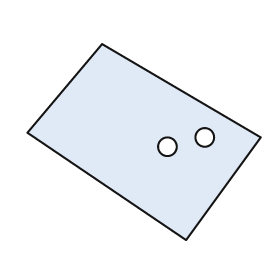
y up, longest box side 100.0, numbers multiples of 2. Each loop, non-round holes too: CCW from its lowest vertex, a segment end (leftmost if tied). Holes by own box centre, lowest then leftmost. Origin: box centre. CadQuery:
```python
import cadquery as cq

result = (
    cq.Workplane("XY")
    .moveTo(18.0, -42.0)
    .lineTo(50.0, 2.0)
    .lineTo(-18.0, 42.0)
    .lineTo(-50.0, 4.0)
    .close()
    .moveTo(10.0, -2.0)
    .circle(4.0)
    .moveTo(26.0, 2.0)
    .circle(4.0)
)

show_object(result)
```